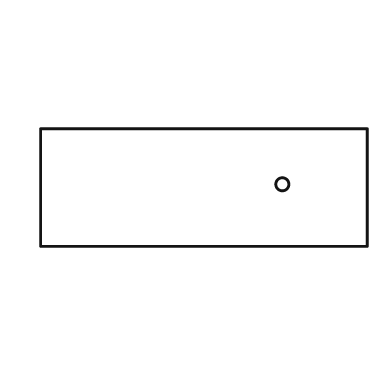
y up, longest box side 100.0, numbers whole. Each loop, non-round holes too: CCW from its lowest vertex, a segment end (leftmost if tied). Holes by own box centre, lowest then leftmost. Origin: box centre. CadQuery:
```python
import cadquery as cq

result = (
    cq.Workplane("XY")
    .moveTo(-50.0, -18.0)
    .lineTo(50.0, -18.0)
    .lineTo(50.0, 18.0)
    .lineTo(-50.0, 18.0)
    .close()
    .moveTo(24.0, 1.0)
    .circle(2.0)
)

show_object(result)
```